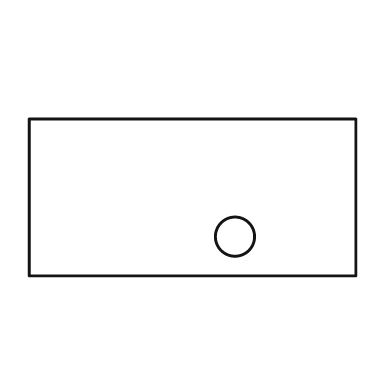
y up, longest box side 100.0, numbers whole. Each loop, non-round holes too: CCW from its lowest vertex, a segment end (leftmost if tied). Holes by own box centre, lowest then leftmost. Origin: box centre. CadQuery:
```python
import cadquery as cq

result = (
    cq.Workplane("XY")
    .moveTo(-50.0, -24.0)
    .lineTo(50.0, -24.0)
    .lineTo(50.0, 24.0)
    .lineTo(-50.0, 24.0)
    .close()
    .moveTo(13.0, -12.0)
    .circle(6.0)
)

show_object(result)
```